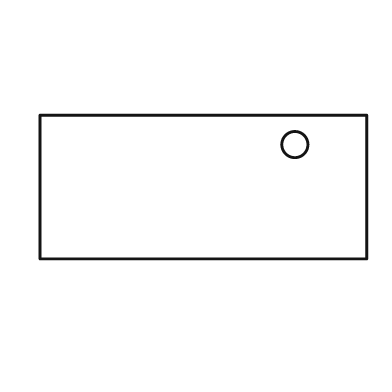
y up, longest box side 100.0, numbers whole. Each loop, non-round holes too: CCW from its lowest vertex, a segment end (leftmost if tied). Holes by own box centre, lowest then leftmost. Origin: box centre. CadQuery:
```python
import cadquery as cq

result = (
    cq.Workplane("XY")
    .moveTo(-50.0, -22.0)
    .lineTo(50.0, -22.0)
    .lineTo(50.0, 22.0)
    .lineTo(-50.0, 22.0)
    .close()
    .moveTo(28.0, 13.0)
    .circle(4.0)
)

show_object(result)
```